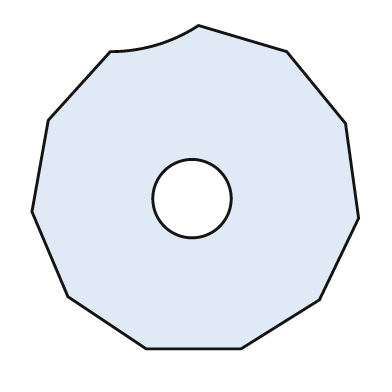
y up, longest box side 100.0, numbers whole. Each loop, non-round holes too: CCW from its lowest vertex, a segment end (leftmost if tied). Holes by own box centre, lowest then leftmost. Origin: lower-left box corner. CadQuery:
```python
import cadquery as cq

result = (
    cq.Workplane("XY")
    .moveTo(35.0, 0.0)
    .lineTo(64.0, 0.0)
    .lineTo(88.0, 15.0)
    .lineTo(100.0, 40.0)
    .lineTo(96.0, 69.0)
    .lineTo(78.0, 91.0)
    .lineTo(51.0, 99.0)
    .threePointArc((38.0, 93.0), (24.0, 91.0))
    .lineTo(5.0, 70.0)
    .lineTo(0.0, 42.0)
    .lineTo(11.0, 16.0)
    .close()
    .moveTo(49.0, 46.0)
    .circle(12.0)
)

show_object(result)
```